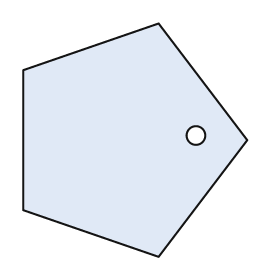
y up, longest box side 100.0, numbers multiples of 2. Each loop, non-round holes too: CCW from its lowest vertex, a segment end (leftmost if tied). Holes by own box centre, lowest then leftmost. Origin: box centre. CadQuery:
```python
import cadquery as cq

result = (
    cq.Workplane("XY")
    .moveTo(10.0, -50.0)
    .lineTo(48.0, 0.0)
    .lineTo(10.0, 50.0)
    .lineTo(-48.0, 30.0)
    .lineTo(-48.0, -30.0)
    .close()
    .moveTo(26.0, 2.0)
    .circle(4.0)
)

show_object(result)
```